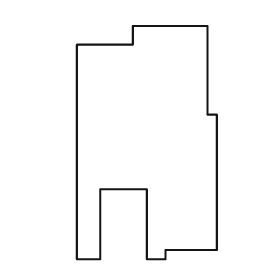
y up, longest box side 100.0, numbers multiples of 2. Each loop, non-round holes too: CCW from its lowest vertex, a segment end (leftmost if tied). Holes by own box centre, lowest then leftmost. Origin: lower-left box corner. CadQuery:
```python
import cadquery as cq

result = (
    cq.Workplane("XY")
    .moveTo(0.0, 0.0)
    .lineTo(10.0, 0.0)
    .lineTo(10.0, 30.0)
    .lineTo(30.0, 30.0)
    .lineTo(30.0, 0.0)
    .lineTo(38.0, 0.0)
    .lineTo(38.0, 4.0)
    .lineTo(60.0, 4.0)
    .lineTo(60.0, 62.0)
    .lineTo(56.0, 62.0)
    .lineTo(56.0, 100.0)
    .lineTo(24.0, 100.0)
    .lineTo(24.0, 92.0)
    .lineTo(0.0, 92.0)
    .close()
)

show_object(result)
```